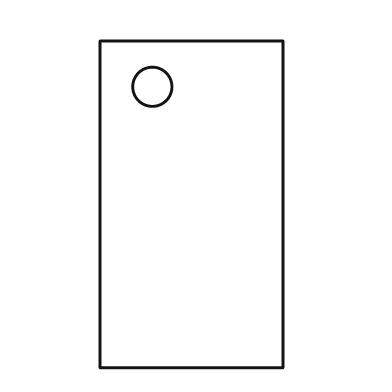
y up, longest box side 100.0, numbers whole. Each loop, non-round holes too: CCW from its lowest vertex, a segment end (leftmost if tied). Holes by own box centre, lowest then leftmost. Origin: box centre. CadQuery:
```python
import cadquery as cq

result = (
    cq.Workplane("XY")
    .moveTo(-28.0, -50.0)
    .lineTo(28.0, -50.0)
    .lineTo(28.0, 50.0)
    .lineTo(-28.0, 50.0)
    .close()
    .moveTo(-12.0, 36.0)
    .circle(6.0)
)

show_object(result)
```